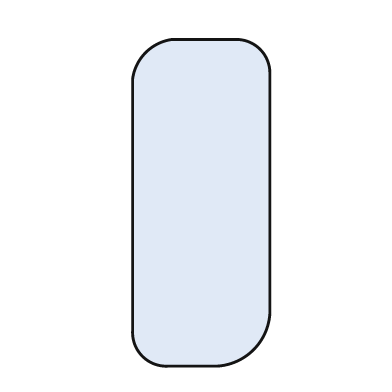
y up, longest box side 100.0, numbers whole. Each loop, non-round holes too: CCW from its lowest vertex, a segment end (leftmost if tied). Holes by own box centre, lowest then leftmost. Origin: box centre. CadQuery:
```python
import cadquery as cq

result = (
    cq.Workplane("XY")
    .moveTo(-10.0, -50.0)
    .lineTo(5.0, -50.0)
    .threePointArc((16.0, -45.0), (21.0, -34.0))
    .lineTo(21.0, 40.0)
    .threePointArc((18.0, 47.0), (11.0, 50.0))
    .lineTo(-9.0, 50.0)
    .threePointArc((-17.0, 46.0), (-21.0, 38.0))
    .lineTo(-21.0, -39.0)
    .threePointArc((-18.0, -47.0), (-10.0, -50.0))
    .close()
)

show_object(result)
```